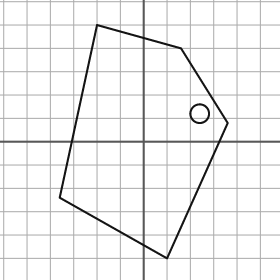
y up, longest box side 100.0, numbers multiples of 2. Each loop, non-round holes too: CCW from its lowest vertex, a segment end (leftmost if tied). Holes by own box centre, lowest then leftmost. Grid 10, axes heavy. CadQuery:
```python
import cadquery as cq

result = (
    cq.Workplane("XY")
    .moveTo(10.0, -50.0)
    .lineTo(36.0, 8.0)
    .lineTo(16.0, 40.0)
    .lineTo(-20.0, 50.0)
    .lineTo(-36.0, -24.0)
    .close()
    .moveTo(24.0, 12.0)
    .circle(4.0)
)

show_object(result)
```